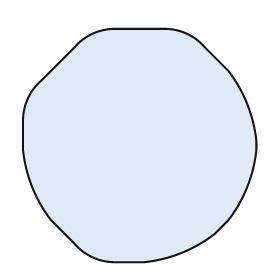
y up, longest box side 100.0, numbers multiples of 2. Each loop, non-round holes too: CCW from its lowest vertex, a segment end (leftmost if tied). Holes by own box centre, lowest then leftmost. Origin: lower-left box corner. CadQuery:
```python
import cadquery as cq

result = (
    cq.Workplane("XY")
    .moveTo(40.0, 0.0)
    .lineTo(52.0, 0.0)
    .threePointArc((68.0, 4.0), (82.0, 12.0))
    .lineTo(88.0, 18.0)
    .threePointArc((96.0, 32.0), (100.0, 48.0))
    .lineTo(100.0, 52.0)
    .threePointArc((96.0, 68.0), (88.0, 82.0))
    .lineTo(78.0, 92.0)
    .threePointArc((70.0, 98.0), (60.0, 100.0))
    .lineTo(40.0, 100.0)
    .threePointArc((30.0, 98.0), (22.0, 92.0))
    .lineTo(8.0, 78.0)
    .threePointArc((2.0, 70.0), (0.0, 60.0))
    .lineTo(0.0, 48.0)
    .threePointArc((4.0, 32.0), (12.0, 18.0))
    .lineTo(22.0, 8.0)
    .threePointArc((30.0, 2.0), (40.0, 0.0))
    .close()
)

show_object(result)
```